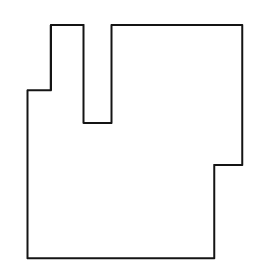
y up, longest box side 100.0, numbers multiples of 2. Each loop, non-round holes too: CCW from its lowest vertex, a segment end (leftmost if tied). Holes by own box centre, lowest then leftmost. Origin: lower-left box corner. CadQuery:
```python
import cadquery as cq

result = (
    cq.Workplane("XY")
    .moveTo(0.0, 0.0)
    .lineTo(80.0, 0.0)
    .lineTo(80.0, 40.0)
    .lineTo(92.0, 40.0)
    .lineTo(92.0, 100.0)
    .lineTo(36.0, 100.0)
    .lineTo(36.0, 58.0)
    .lineTo(24.0, 58.0)
    .lineTo(24.0, 100.0)
    .lineTo(10.0, 100.0)
    .lineTo(10.0, 72.0)
    .lineTo(0.0, 72.0)
    .close()
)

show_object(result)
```